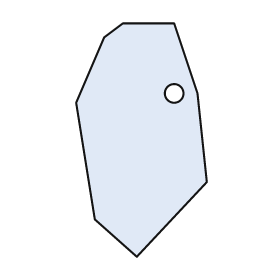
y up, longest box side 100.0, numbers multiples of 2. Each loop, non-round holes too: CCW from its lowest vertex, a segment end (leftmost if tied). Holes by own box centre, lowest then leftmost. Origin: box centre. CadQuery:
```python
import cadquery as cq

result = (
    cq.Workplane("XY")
    .moveTo(-2.0, -50.0)
    .lineTo(28.0, -18.0)
    .lineTo(24.0, 20.0)
    .lineTo(14.0, 50.0)
    .lineTo(-8.0, 50.0)
    .lineTo(-16.0, 44.0)
    .lineTo(-28.0, 16.0)
    .lineTo(-20.0, -34.0)
    .close()
    .moveTo(14.0, 20.0)
    .circle(4.0)
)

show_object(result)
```